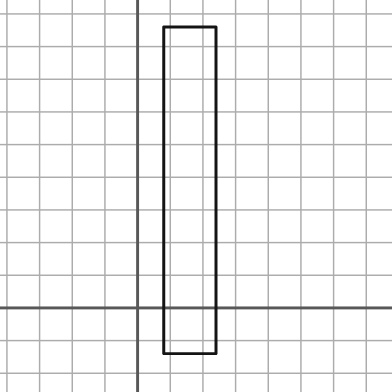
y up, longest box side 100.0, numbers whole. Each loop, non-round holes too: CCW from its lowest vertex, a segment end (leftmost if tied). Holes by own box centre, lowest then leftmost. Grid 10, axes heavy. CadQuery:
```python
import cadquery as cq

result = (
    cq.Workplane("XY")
    .moveTo(8.0, -14.0)
    .lineTo(24.0, -14.0)
    .lineTo(24.0, 86.0)
    .lineTo(8.0, 86.0)
    .close()
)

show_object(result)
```